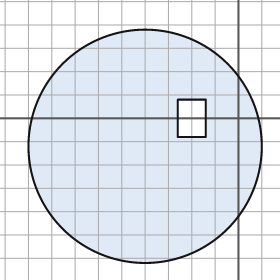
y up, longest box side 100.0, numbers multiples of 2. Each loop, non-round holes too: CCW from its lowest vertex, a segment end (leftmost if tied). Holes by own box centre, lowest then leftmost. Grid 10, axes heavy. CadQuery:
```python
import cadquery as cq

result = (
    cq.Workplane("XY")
    .moveTo(-40.0, -12.0)
    .circle(50.0)
    .moveTo(-26.0, -8.0)
    .lineTo(-14.0, -8.0)
    .lineTo(-14.0, 8.0)
    .lineTo(-26.0, 8.0)
    .close()
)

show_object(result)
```